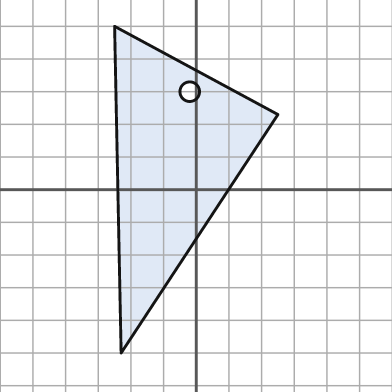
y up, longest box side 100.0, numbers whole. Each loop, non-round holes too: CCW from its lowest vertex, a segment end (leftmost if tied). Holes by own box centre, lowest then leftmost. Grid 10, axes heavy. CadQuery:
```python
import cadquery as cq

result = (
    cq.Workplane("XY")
    .moveTo(-23.0, -50.0)
    .lineTo(25.0, 23.0)
    .lineTo(-25.0, 50.0)
    .close()
    .moveTo(-2.0, 30.0)
    .circle(3.0)
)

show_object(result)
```